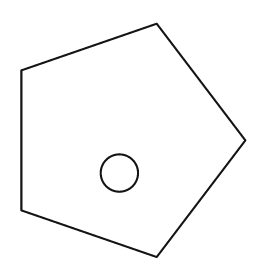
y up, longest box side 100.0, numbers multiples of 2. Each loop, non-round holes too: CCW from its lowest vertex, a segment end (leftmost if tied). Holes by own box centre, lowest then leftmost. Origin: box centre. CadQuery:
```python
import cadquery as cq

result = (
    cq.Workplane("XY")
    .moveTo(10.0, -50.0)
    .lineTo(48.0, 0.0)
    .lineTo(10.0, 50.0)
    .lineTo(-48.0, 30.0)
    .lineTo(-48.0, -30.0)
    .close()
    .moveTo(-6.0, -14.0)
    .circle(8.0)
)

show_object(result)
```